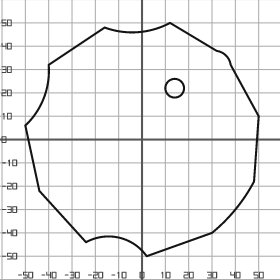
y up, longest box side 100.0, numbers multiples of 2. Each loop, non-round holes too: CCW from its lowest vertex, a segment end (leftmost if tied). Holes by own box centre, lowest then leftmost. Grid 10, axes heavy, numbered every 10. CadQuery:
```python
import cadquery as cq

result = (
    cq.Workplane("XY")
    .moveTo(2.0, -50.0)
    .lineTo(30.0, -40.0)
    .threePointArc((40.0, -30.0), (48.0, -18.0))
    .lineTo(50.0, 10.0)
    .lineTo(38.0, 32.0)
    .threePointArc((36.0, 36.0), (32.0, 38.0))
    .lineTo(12.0, 50.0)
    .threePointArc((-2.0, 46.0), (-16.0, 48.0))
    .lineTo(-40.0, 32.0)
    .threePointArc((-42.0, 18.0), (-50.0, 6.0))
    .lineTo(-44.0, -22.0)
    .lineTo(-24.0, -44.0)
    .threePointArc((-10.0, -42.0), (2.0, -50.0))
    .close()
    .moveTo(14.0, 22.0)
    .circle(4.0)
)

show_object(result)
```